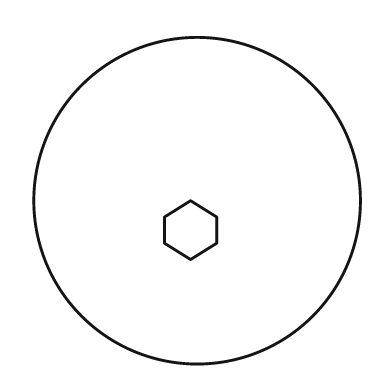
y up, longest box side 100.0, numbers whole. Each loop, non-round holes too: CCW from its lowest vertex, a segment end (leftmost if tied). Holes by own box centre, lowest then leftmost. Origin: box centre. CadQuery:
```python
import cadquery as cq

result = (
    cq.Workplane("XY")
    .moveTo(0.0, 0.0)
    .circle(50.0)
    .moveTo(-2.0, -18.0)
    .lineTo(6.0, -13.0)
    .lineTo(6.0, -5.0)
    .lineTo(-2.0, 0.0)
    .lineTo(-10.0, -5.0)
    .lineTo(-10.0, -13.0)
    .close()
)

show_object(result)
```